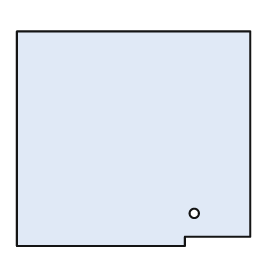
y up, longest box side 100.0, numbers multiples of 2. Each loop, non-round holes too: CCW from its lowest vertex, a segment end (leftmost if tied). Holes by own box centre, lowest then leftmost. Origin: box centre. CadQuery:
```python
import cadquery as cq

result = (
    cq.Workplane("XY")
    .moveTo(-50.0, -46.0)
    .lineTo(22.0, -46.0)
    .lineTo(22.0, -42.0)
    .lineTo(50.0, -42.0)
    .lineTo(50.0, 46.0)
    .lineTo(-50.0, 46.0)
    .close()
    .moveTo(26.0, -32.0)
    .circle(2.0)
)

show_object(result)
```